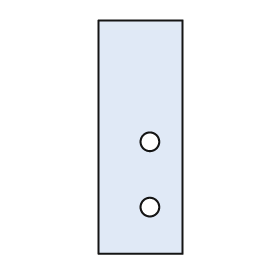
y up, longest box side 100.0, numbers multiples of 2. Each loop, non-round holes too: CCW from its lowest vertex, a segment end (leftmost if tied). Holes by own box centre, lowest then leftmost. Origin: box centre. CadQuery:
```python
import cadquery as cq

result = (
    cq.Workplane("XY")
    .moveTo(-18.0, -50.0)
    .lineTo(18.0, -50.0)
    .lineTo(18.0, 50.0)
    .lineTo(-18.0, 50.0)
    .close()
    .moveTo(4.0, -30.0)
    .circle(4.0)
    .moveTo(4.0, -2.0)
    .circle(4.0)
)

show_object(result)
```